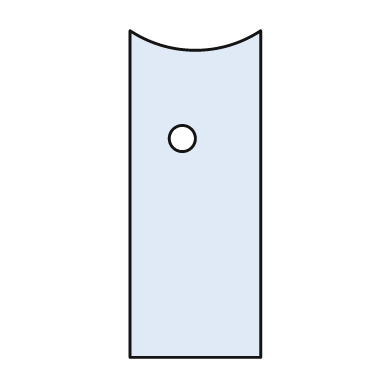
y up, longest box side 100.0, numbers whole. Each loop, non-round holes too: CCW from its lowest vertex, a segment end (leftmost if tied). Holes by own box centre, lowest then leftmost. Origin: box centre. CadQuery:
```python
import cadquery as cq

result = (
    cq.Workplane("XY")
    .moveTo(-20.0, -50.0)
    .lineTo(20.0, -50.0)
    .lineTo(20.0, 50.0)
    .threePointArc((0.0, 44.0), (-20.0, 50.0))
    .close()
    .moveTo(-4.0, 17.0)
    .circle(4.0)
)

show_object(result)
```